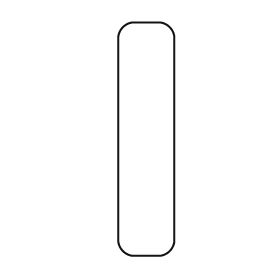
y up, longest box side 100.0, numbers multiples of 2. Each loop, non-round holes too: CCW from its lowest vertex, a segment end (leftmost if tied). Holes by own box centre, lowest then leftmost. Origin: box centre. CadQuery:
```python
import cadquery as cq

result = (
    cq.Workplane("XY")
    .moveTo(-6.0, -50.0)
    .lineTo(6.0, -50.0)
    .threePointArc((10.0, -48.0), (12.0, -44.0))
    .lineTo(12.0, 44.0)
    .threePointArc((10.0, 48.0), (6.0, 50.0))
    .lineTo(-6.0, 50.0)
    .threePointArc((-10.0, 48.0), (-12.0, 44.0))
    .lineTo(-12.0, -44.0)
    .threePointArc((-10.0, -48.0), (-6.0, -50.0))
    .close()
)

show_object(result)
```